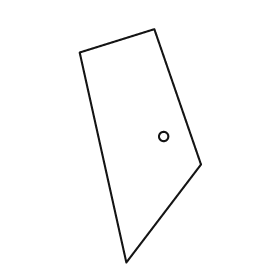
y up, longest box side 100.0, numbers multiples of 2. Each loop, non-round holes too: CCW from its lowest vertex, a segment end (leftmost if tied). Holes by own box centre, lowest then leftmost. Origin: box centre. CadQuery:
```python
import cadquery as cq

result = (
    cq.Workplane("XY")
    .moveTo(-6.0, -50.0)
    .lineTo(26.0, -8.0)
    .lineTo(6.0, 50.0)
    .lineTo(-26.0, 40.0)
    .close()
    .moveTo(10.0, 4.0)
    .circle(2.0)
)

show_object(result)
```